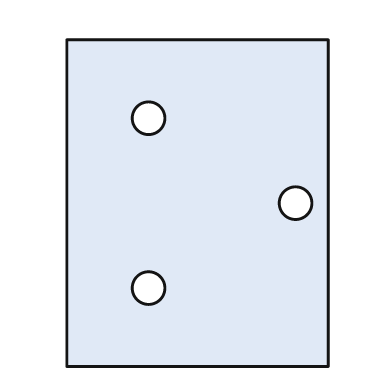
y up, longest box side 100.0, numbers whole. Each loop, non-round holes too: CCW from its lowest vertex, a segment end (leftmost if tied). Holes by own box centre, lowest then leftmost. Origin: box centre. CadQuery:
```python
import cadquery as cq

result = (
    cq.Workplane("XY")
    .moveTo(-40.0, -50.0)
    .lineTo(40.0, -50.0)
    .lineTo(40.0, 50.0)
    .lineTo(-40.0, 50.0)
    .close()
    .moveTo(-15.0, -26.0)
    .circle(5.0)
    .moveTo(30.0, 0.0)
    .circle(5.0)
    .moveTo(-15.0, 26.0)
    .circle(5.0)
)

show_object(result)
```